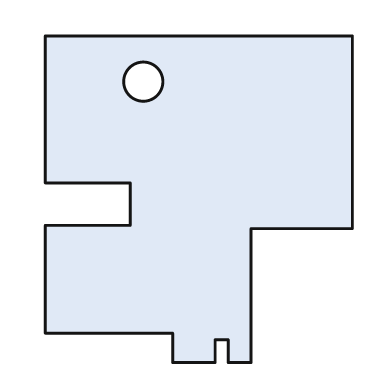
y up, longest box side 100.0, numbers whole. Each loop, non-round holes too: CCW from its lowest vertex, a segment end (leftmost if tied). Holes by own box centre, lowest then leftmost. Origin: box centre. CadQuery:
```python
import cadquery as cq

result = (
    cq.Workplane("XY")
    .moveTo(-8.0, -50.0)
    .lineTo(5.0, -50.0)
    .lineTo(5.0, -43.0)
    .lineTo(9.0, -43.0)
    .lineTo(9.0, -50.0)
    .lineTo(16.0, -50.0)
    .lineTo(16.0, -9.0)
    .lineTo(47.0, -9.0)
    .lineTo(47.0, 50.0)
    .lineTo(-47.0, 50.0)
    .lineTo(-47.0, 5.0)
    .lineTo(-21.0, 5.0)
    .lineTo(-21.0, -8.0)
    .lineTo(-47.0, -8.0)
    .lineTo(-47.0, -41.0)
    .lineTo(-8.0, -41.0)
    .close()
    .moveTo(-17.0, 36.0)
    .circle(6.0)
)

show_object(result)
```